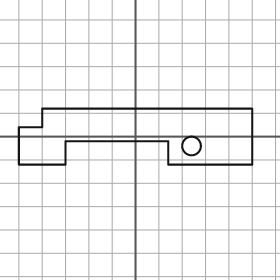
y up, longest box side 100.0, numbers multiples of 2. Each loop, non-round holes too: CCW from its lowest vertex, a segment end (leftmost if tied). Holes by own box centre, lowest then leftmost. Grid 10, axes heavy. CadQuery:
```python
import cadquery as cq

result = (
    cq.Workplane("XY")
    .moveTo(-50.0, -12.0)
    .lineTo(-30.0, -12.0)
    .lineTo(-30.0, -2.0)
    .lineTo(14.0, -2.0)
    .lineTo(14.0, -12.0)
    .lineTo(50.0, -12.0)
    .lineTo(50.0, 12.0)
    .lineTo(-40.0, 12.0)
    .lineTo(-40.0, 4.0)
    .lineTo(-50.0, 4.0)
    .close()
    .moveTo(24.0, -4.0)
    .circle(4.0)
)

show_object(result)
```